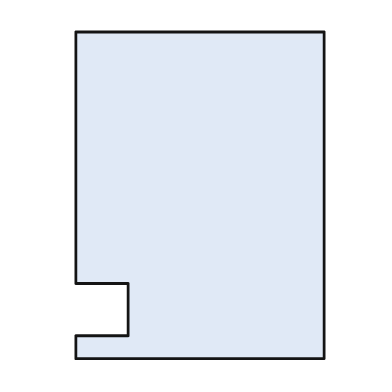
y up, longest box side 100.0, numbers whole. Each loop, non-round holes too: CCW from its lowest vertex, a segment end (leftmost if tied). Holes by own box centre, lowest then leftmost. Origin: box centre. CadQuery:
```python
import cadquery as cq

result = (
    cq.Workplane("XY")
    .moveTo(-38.0, -50.0)
    .lineTo(38.0, -50.0)
    .lineTo(38.0, 50.0)
    .lineTo(-38.0, 50.0)
    .lineTo(-38.0, -27.0)
    .lineTo(-22.0, -27.0)
    .lineTo(-22.0, -43.0)
    .lineTo(-38.0, -43.0)
    .close()
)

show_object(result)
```